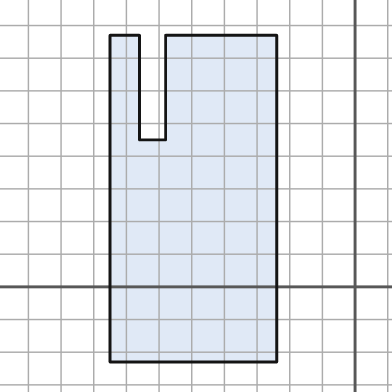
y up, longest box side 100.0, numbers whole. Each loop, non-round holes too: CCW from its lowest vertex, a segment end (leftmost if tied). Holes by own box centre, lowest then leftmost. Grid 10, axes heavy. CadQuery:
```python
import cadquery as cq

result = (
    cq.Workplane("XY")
    .moveTo(-75.0, -23.0)
    .lineTo(-24.0, -23.0)
    .lineTo(-24.0, 77.0)
    .lineTo(-58.0, 77.0)
    .lineTo(-58.0, 45.0)
    .lineTo(-66.0, 45.0)
    .lineTo(-66.0, 77.0)
    .lineTo(-75.0, 77.0)
    .close()
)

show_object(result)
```